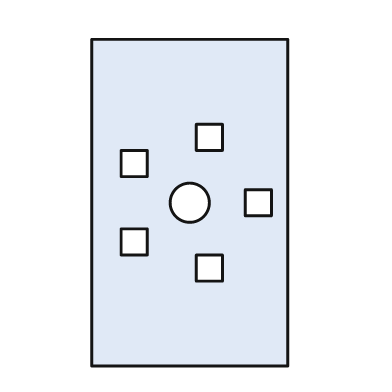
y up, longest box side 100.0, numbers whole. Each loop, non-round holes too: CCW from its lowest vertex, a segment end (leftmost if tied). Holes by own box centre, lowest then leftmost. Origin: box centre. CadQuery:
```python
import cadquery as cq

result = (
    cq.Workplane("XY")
    .moveTo(-30.0, -50.0)
    .lineTo(30.0, -50.0)
    .lineTo(30.0, 50.0)
    .lineTo(-30.0, 50.0)
    .close()
    .moveTo(2.0, -24.0)
    .lineTo(10.0, -24.0)
    .lineTo(10.0, -16.0)
    .lineTo(2.0, -16.0)
    .close()
    .moveTo(-21.0, -16.0)
    .lineTo(-13.0, -16.0)
    .lineTo(-13.0, -8.0)
    .lineTo(-21.0, -8.0)
    .close()
    .moveTo(0.0, 0.0)
    .circle(6.0)
    .moveTo(17.0, -4.0)
    .lineTo(25.0, -4.0)
    .lineTo(25.0, 4.0)
    .lineTo(17.0, 4.0)
    .close()
    .moveTo(-21.0, 8.0)
    .lineTo(-13.0, 8.0)
    .lineTo(-13.0, 16.0)
    .lineTo(-21.0, 16.0)
    .close()
    .moveTo(2.0, 16.0)
    .lineTo(10.0, 16.0)
    .lineTo(10.0, 24.0)
    .lineTo(2.0, 24.0)
    .close()
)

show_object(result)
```